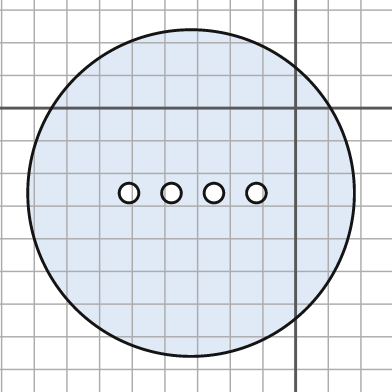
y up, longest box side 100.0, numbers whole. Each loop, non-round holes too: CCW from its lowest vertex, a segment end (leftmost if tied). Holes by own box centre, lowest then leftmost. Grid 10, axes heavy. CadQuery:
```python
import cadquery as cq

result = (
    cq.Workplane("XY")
    .moveTo(-32.0, -26.0)
    .circle(50.0)
    .moveTo(-51.0, -26.0)
    .circle(3.0)
    .moveTo(-38.0, -26.0)
    .circle(3.0)
    .moveTo(-25.0, -26.0)
    .circle(3.0)
    .moveTo(-12.0, -26.0)
    .circle(3.0)
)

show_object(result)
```